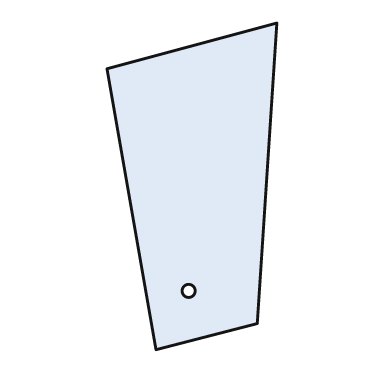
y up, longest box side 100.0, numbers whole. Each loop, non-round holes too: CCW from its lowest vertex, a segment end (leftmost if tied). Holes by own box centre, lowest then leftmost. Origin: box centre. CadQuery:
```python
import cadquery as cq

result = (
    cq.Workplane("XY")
    .moveTo(-11.0, -50.0)
    .lineTo(20.0, -42.0)
    .lineTo(26.0, 50.0)
    .lineTo(-26.0, 36.0)
    .close()
    .moveTo(-1.0, -32.0)
    .circle(2.0)
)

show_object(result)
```